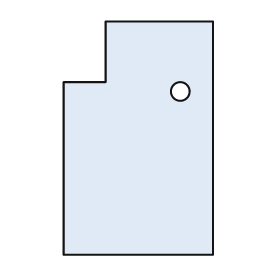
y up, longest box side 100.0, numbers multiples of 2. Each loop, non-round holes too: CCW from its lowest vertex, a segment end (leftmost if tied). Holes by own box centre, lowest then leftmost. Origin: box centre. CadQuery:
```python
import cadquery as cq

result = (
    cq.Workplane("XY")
    .moveTo(-32.0, -50.0)
    .lineTo(32.0, -50.0)
    .lineTo(32.0, 50.0)
    .lineTo(-14.0, 50.0)
    .lineTo(-14.0, 24.0)
    .lineTo(-32.0, 24.0)
    .close()
    .moveTo(18.0, 20.0)
    .circle(4.0)
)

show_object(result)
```